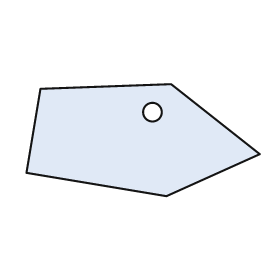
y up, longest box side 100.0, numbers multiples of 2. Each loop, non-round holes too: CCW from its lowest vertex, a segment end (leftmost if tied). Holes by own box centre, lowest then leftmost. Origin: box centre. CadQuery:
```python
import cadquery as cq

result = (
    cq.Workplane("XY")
    .moveTo(10.0, -24.0)
    .lineTo(50.0, -6.0)
    .lineTo(12.0, 24.0)
    .lineTo(-44.0, 22.0)
    .lineTo(-50.0, -14.0)
    .close()
    .moveTo(4.0, 12.0)
    .circle(4.0)
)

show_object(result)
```